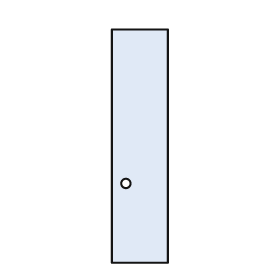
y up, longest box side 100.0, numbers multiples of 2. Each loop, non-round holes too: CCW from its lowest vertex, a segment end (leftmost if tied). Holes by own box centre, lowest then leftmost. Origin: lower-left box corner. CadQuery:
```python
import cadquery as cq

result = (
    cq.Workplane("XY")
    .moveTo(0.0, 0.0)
    .lineTo(24.0, 0.0)
    .lineTo(24.0, 100.0)
    .lineTo(0.0, 100.0)
    .close()
    .moveTo(6.0, 34.0)
    .circle(2.0)
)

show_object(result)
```